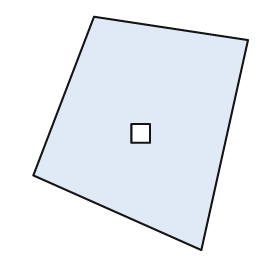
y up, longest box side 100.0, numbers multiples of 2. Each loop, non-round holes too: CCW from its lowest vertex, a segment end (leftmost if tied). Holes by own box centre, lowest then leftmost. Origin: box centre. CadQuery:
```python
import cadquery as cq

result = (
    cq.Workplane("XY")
    .moveTo(26.0, -50.0)
    .lineTo(46.0, 40.0)
    .lineTo(-20.0, 50.0)
    .lineTo(-46.0, -18.0)
    .close()
    .moveTo(-4.0, -4.0)
    .lineTo(4.0, -4.0)
    .lineTo(4.0, 4.0)
    .lineTo(-4.0, 4.0)
    .close()
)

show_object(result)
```